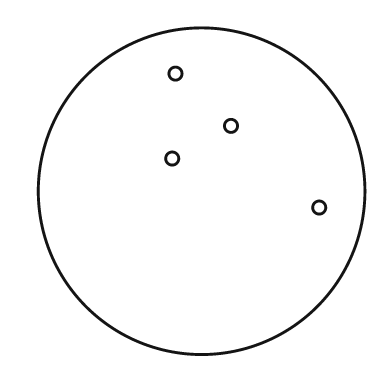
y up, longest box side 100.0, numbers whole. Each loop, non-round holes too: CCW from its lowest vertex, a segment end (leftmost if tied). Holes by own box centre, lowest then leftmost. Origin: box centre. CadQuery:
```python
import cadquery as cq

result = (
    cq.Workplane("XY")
    .moveTo(0.0, 0.0)
    .circle(50.0)
    .moveTo(36.0, -5.0)
    .circle(2.0)
    .moveTo(-9.0, 10.0)
    .circle(2.0)
    .moveTo(9.0, 20.0)
    .circle(2.0)
    .moveTo(-8.0, 36.0)
    .circle(2.0)
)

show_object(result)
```